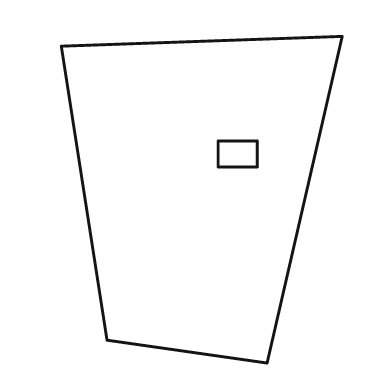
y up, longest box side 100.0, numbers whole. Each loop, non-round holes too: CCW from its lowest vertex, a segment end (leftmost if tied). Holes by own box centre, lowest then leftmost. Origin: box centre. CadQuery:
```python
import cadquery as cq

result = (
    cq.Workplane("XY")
    .moveTo(20.0, -50.0)
    .lineTo(43.0, 50.0)
    .lineTo(-43.0, 47.0)
    .lineTo(-29.0, -43.0)
    .close()
    .moveTo(5.0, 10.0)
    .lineTo(17.0, 10.0)
    .lineTo(17.0, 18.0)
    .lineTo(5.0, 18.0)
    .close()
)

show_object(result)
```